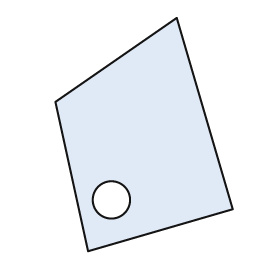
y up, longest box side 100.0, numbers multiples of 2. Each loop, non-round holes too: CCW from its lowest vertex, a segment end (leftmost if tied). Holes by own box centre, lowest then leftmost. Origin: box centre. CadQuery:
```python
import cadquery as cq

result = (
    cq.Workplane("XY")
    .moveTo(-24.0, -50.0)
    .lineTo(38.0, -32.0)
    .lineTo(14.0, 50.0)
    .lineTo(-38.0, 14.0)
    .close()
    .moveTo(-14.0, -28.0)
    .circle(8.0)
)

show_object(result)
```